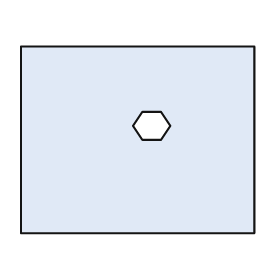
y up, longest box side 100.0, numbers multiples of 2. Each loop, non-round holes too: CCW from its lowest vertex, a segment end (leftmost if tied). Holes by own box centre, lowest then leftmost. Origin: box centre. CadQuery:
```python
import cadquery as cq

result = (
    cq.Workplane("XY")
    .moveTo(-50.0, -40.0)
    .lineTo(50.0, -40.0)
    .lineTo(50.0, 40.0)
    .lineTo(-50.0, 40.0)
    .close()
    .moveTo(2.0, 0.0)
    .lineTo(10.0, 0.0)
    .lineTo(14.0, 6.0)
    .lineTo(10.0, 12.0)
    .lineTo(2.0, 12.0)
    .lineTo(-2.0, 6.0)
    .close()
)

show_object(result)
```